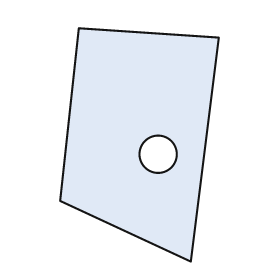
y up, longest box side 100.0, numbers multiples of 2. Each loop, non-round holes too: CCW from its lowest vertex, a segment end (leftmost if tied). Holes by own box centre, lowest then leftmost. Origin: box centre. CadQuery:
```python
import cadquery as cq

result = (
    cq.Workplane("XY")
    .moveTo(22.0, -50.0)
    .lineTo(34.0, 46.0)
    .lineTo(-26.0, 50.0)
    .lineTo(-34.0, -24.0)
    .close()
    .moveTo(8.0, -4.0)
    .circle(8.0)
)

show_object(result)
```